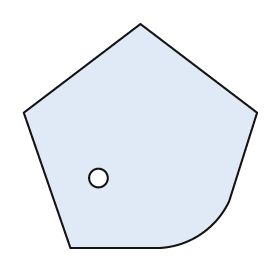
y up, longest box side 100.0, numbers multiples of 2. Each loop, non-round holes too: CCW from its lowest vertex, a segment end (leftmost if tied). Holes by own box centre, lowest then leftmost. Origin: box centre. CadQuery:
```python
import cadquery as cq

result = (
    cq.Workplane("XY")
    .moveTo(-30.0, -48.0)
    .lineTo(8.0, -48.0)
    .threePointArc((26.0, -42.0), (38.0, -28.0))
    .lineTo(50.0, 10.0)
    .lineTo(0.0, 48.0)
    .lineTo(-50.0, 10.0)
    .close()
    .moveTo(-18.0, -18.0)
    .circle(4.0)
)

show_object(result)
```